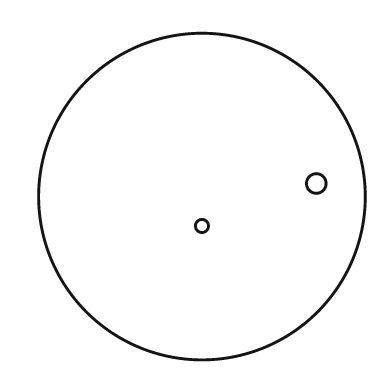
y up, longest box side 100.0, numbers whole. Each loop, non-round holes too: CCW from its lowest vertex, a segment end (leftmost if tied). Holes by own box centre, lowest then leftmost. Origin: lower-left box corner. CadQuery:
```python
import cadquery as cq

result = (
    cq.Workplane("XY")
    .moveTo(50.0, 50.0)
    .circle(50.0)
    .moveTo(50.0, 41.0)
    .circle(2.0)
    .moveTo(85.0, 54.0)
    .circle(3.0)
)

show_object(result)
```